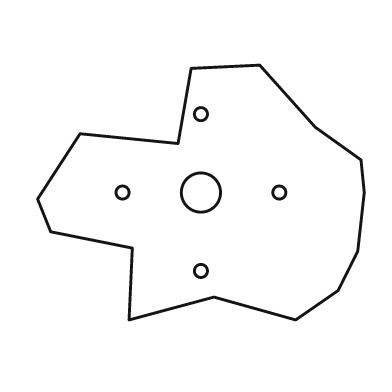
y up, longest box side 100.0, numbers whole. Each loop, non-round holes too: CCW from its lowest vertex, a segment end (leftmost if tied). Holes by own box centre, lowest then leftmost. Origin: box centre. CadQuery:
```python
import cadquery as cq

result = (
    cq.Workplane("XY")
    .moveTo(-22.0, -39.0)
    .lineTo(4.0, -32.0)
    .lineTo(29.0, -39.0)
    .lineTo(42.0, -30.0)
    .lineTo(48.0, -18.0)
    .lineTo(50.0, 0.0)
    .lineTo(49.0, 10.0)
    .lineTo(35.0, 20.0)
    .lineTo(18.0, 39.0)
    .lineTo(-3.0, 38.0)
    .lineTo(-7.0, 15.0)
    .lineTo(-37.0, 18.0)
    .lineTo(-50.0, -2.0)
    .lineTo(-46.0, -12.0)
    .lineTo(-21.0, -17.0)
    .close()
    .moveTo(0.0, -24.0)
    .circle(2.0)
    .moveTo(-24.0, 0.0)
    .circle(2.0)
    .moveTo(0.0, 0.0)
    .circle(6.0)
    .moveTo(24.0, 0.0)
    .circle(2.0)
    .moveTo(0.0, 24.0)
    .circle(2.0)
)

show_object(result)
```